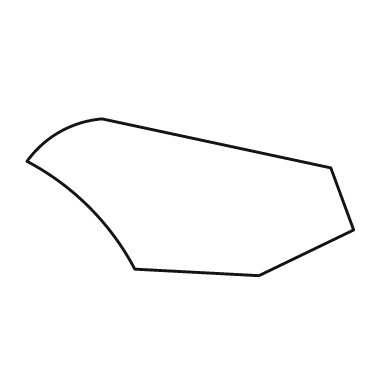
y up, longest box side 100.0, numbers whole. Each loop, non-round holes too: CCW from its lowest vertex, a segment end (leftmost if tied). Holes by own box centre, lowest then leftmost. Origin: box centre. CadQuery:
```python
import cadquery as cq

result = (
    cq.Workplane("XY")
    .moveTo(21.0, -24.0)
    .lineTo(50.0, -10.0)
    .lineTo(43.0, 9.0)
    .lineTo(-27.0, 24.0)
    .threePointArc((-40.0, 20.0), (-50.0, 11.0))
    .threePointArc((-31.0, -3.0), (-17.0, -22.0))
    .close()
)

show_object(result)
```